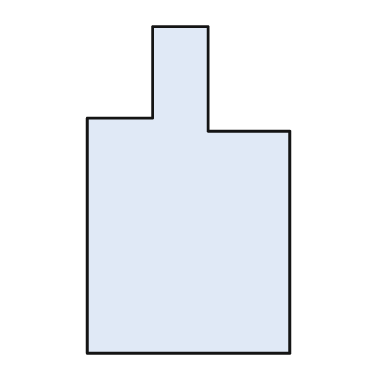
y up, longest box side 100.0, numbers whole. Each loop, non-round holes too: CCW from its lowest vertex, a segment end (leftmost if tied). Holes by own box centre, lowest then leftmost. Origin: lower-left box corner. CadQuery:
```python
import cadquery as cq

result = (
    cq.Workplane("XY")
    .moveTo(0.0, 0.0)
    .lineTo(62.0, 0.0)
    .lineTo(62.0, 68.0)
    .lineTo(37.0, 68.0)
    .lineTo(37.0, 100.0)
    .lineTo(20.0, 100.0)
    .lineTo(20.0, 72.0)
    .lineTo(0.0, 72.0)
    .close()
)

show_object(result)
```